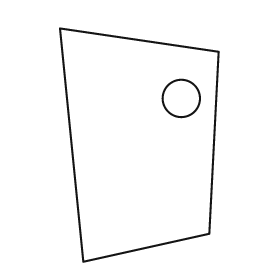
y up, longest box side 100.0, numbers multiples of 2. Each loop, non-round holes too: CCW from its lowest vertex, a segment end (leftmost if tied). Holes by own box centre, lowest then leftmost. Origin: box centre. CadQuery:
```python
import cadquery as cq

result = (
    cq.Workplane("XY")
    .moveTo(-24.0, -50.0)
    .lineTo(30.0, -38.0)
    .lineTo(34.0, 40.0)
    .lineTo(-34.0, 50.0)
    .close()
    .moveTo(18.0, 20.0)
    .circle(8.0)
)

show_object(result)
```